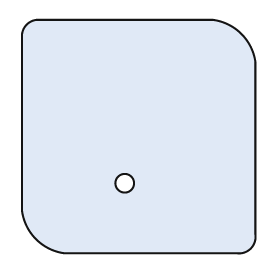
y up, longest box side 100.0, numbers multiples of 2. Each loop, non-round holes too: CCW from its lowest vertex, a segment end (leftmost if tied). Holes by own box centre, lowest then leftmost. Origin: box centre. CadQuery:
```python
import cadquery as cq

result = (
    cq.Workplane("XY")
    .moveTo(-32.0, -50.0)
    .lineTo(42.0, -50.0)
    .threePointArc((48.0, -48.0), (50.0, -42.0))
    .lineTo(50.0, 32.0)
    .threePointArc((44.0, 44.0), (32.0, 50.0))
    .lineTo(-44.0, 50.0)
    .threePointArc((-48.0, 48.0), (-50.0, 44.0))
    .lineTo(-50.0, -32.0)
    .threePointArc((-44.0, -44.0), (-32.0, -50.0))
    .close()
    .moveTo(-6.0, -20.0)
    .circle(4.0)
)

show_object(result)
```